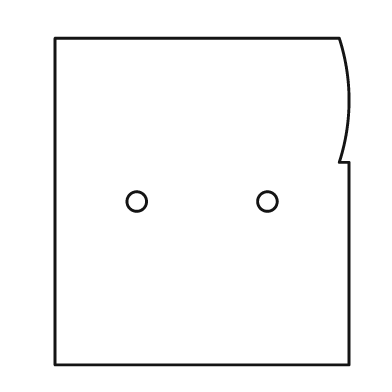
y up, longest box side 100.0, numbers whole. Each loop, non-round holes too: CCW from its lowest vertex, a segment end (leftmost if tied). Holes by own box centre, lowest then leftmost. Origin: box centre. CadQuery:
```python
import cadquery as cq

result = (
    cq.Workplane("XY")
    .moveTo(-45.0, -50.0)
    .lineTo(45.0, -50.0)
    .lineTo(45.0, 12.0)
    .lineTo(42.0, 12.0)
    .threePointArc((45.0, 31.0), (42.0, 50.0))
    .lineTo(-45.0, 50.0)
    .close()
    .moveTo(-20.0, 0.0)
    .circle(3.0)
    .moveTo(20.0, 0.0)
    .circle(3.0)
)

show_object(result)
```